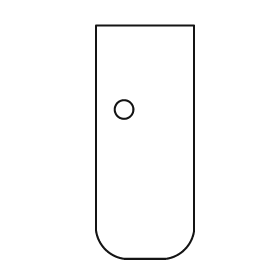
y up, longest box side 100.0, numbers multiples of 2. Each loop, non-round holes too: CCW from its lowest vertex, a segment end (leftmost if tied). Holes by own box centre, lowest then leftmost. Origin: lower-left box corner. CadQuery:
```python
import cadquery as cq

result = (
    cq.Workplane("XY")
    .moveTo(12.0, 0.0)
    .lineTo(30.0, 0.0)
    .threePointArc((38.0, 4.0), (42.0, 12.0))
    .lineTo(42.0, 100.0)
    .lineTo(0.0, 100.0)
    .lineTo(0.0, 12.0)
    .threePointArc((4.0, 4.0), (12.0, 0.0))
    .close()
    .moveTo(12.0, 64.0)
    .circle(4.0)
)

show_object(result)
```